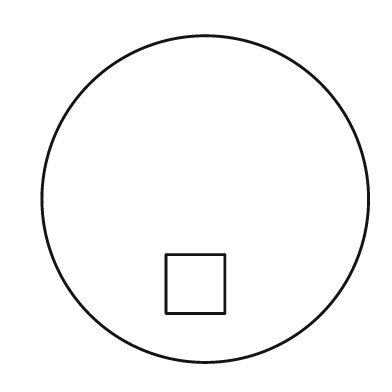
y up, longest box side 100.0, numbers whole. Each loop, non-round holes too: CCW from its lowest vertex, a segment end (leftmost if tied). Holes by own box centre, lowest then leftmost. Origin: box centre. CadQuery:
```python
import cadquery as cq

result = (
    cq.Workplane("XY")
    .moveTo(0.0, 0.0)
    .circle(50.0)
    .moveTo(-12.0, -35.0)
    .lineTo(6.0, -35.0)
    .lineTo(6.0, -17.0)
    .lineTo(-12.0, -17.0)
    .close()
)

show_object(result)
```